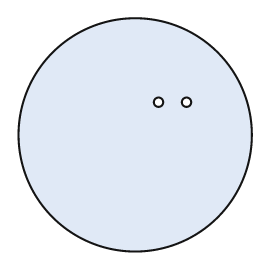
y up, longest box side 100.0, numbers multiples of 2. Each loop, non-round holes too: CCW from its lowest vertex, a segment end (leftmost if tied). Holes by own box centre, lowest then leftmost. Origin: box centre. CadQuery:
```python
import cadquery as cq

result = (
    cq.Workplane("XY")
    .moveTo(0.0, 0.0)
    .circle(50.0)
    .moveTo(10.0, 14.0)
    .circle(2.0)
    .moveTo(22.0, 14.0)
    .circle(2.0)
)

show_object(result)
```